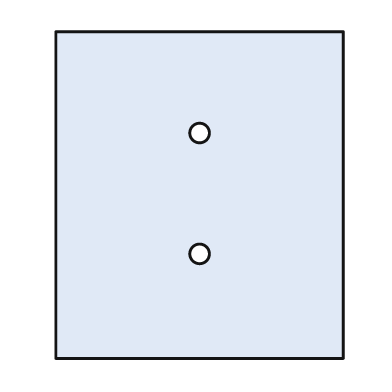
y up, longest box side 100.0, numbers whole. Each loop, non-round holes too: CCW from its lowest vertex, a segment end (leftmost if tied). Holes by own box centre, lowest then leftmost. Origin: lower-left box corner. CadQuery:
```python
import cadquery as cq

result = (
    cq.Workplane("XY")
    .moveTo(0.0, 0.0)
    .lineTo(88.0, 0.0)
    .lineTo(88.0, 100.0)
    .lineTo(0.0, 100.0)
    .close()
    .moveTo(44.0, 32.0)
    .circle(3.0)
    .moveTo(44.0, 69.0)
    .circle(3.0)
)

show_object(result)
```